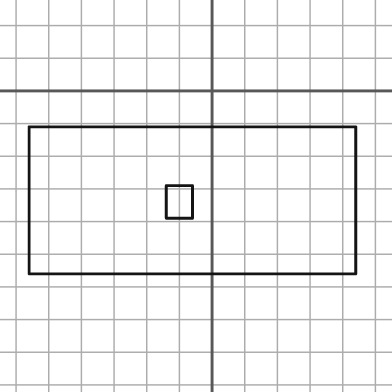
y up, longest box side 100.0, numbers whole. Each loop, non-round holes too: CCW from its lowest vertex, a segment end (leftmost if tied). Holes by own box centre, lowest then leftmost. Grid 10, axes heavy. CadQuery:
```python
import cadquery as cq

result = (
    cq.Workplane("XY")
    .moveTo(-56.0, -56.0)
    .lineTo(44.0, -56.0)
    .lineTo(44.0, -11.0)
    .lineTo(-56.0, -11.0)
    .close()
    .moveTo(-14.0, -39.0)
    .lineTo(-6.0, -39.0)
    .lineTo(-6.0, -29.0)
    .lineTo(-14.0, -29.0)
    .close()
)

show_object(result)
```